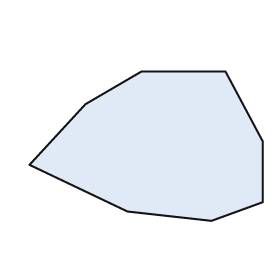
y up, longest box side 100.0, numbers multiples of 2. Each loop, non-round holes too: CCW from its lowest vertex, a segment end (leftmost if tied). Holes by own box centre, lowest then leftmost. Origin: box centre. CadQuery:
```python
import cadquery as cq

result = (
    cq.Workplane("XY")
    .moveTo(28.0, -32.0)
    .lineTo(50.0, -24.0)
    .lineTo(50.0, 2.0)
    .lineTo(34.0, 32.0)
    .lineTo(-2.0, 32.0)
    .lineTo(-26.0, 18.0)
    .lineTo(-50.0, -8.0)
    .lineTo(-8.0, -28.0)
    .close()
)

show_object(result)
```